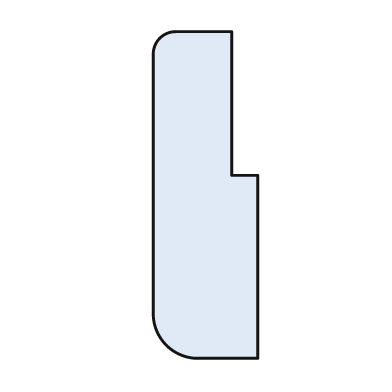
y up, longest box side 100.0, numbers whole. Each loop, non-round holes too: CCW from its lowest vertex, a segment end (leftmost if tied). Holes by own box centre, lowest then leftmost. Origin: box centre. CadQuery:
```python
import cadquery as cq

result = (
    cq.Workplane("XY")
    .moveTo(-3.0, -50.0)
    .lineTo(16.0, -50.0)
    .lineTo(16.0, 6.0)
    .lineTo(8.0, 6.0)
    .lineTo(8.0, 50.0)
    .lineTo(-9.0, 50.0)
    .threePointArc((-14.0, 48.0), (-16.0, 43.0))
    .lineTo(-16.0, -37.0)
    .threePointArc((-12.0, -46.0), (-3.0, -50.0))
    .close()
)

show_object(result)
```